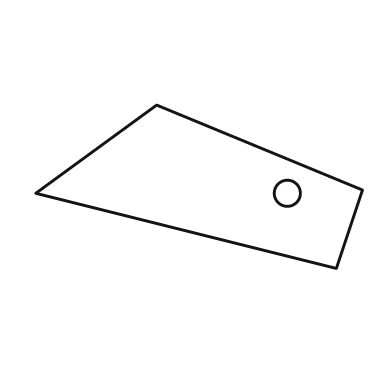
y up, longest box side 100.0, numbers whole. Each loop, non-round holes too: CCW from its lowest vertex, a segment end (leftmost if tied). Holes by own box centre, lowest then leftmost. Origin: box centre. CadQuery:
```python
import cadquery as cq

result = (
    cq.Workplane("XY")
    .moveTo(42.0, -25.0)
    .lineTo(50.0, -1.0)
    .lineTo(-13.0, 25.0)
    .lineTo(-50.0, -2.0)
    .close()
    .moveTo(27.0, -2.0)
    .circle(4.0)
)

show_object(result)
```